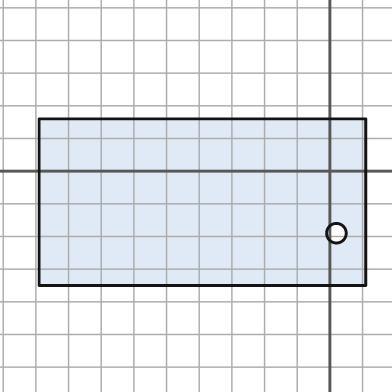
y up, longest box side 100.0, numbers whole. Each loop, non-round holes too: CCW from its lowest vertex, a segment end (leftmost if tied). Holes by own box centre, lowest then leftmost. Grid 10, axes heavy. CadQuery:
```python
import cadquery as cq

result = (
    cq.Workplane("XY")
    .moveTo(-89.0, -35.0)
    .lineTo(11.0, -35.0)
    .lineTo(11.0, 16.0)
    .lineTo(-89.0, 16.0)
    .close()
    .moveTo(2.0, -19.0)
    .circle(3.0)
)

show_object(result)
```